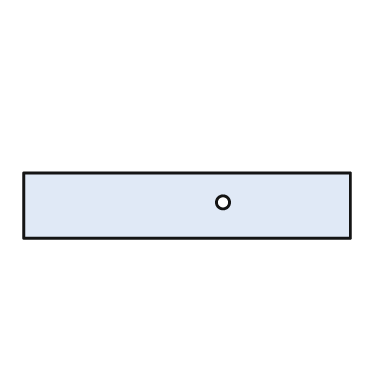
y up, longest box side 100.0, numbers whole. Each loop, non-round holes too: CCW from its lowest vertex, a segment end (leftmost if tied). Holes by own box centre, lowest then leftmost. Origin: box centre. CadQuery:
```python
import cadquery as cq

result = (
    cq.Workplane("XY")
    .moveTo(-50.0, -10.0)
    .lineTo(50.0, -10.0)
    .lineTo(50.0, 10.0)
    .lineTo(-50.0, 10.0)
    .close()
    .moveTo(11.0, 1.0)
    .circle(2.0)
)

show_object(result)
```